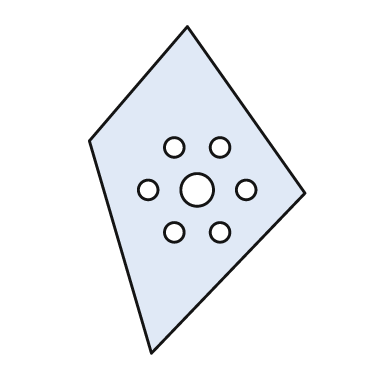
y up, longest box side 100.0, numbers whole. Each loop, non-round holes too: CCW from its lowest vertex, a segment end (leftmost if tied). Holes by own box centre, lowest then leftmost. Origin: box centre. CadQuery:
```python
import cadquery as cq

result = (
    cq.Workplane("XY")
    .moveTo(-14.0, -50.0)
    .lineTo(33.0, -1.0)
    .lineTo(-3.0, 50.0)
    .lineTo(-33.0, 15.0)
    .close()
    .moveTo(-7.0, -13.0)
    .circle(3.0)
    .moveTo(7.0, -13.0)
    .circle(3.0)
    .moveTo(-15.0, 0.0)
    .circle(3.0)
    .moveTo(0.0, 0.0)
    .circle(5.0)
    .moveTo(15.0, 0.0)
    .circle(3.0)
    .moveTo(-7.0, 13.0)
    .circle(3.0)
    .moveTo(7.0, 13.0)
    .circle(3.0)
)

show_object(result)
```